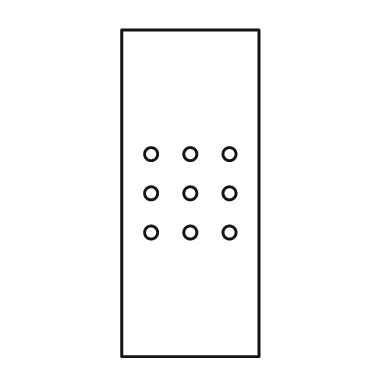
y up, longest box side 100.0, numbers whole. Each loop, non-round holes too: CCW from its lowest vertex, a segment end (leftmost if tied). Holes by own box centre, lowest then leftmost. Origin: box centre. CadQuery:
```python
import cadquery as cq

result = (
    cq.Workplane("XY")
    .moveTo(-21.0, -50.0)
    .lineTo(21.0, -50.0)
    .lineTo(21.0, 50.0)
    .lineTo(-21.0, 50.0)
    .close()
    .moveTo(-12.0, -12.0)
    .circle(2.0)
    .moveTo(0.0, -12.0)
    .circle(2.0)
    .moveTo(12.0, -12.0)
    .circle(2.0)
    .moveTo(-12.0, 0.0)
    .circle(2.0)
    .moveTo(0.0, 0.0)
    .circle(2.0)
    .moveTo(12.0, 0.0)
    .circle(2.0)
    .moveTo(-12.0, 12.0)
    .circle(2.0)
    .moveTo(0.0, 12.0)
    .circle(2.0)
    .moveTo(12.0, 12.0)
    .circle(2.0)
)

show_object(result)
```